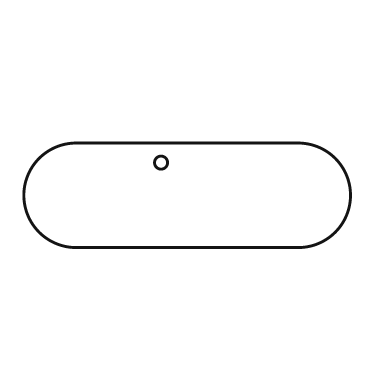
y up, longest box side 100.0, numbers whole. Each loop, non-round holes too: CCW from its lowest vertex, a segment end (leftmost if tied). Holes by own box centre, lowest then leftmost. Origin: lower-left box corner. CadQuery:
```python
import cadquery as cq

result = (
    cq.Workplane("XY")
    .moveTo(16.0, 0.0)
    .lineTo(84.0, 0.0)
    .threePointArc((100.0, 16.0), (84.0, 32.0))
    .lineTo(16.0, 32.0)
    .threePointArc((0.0, 16.0), (16.0, 0.0))
    .close()
    .moveTo(42.0, 26.0)
    .circle(2.0)
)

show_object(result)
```